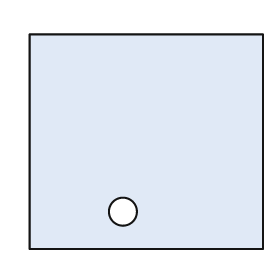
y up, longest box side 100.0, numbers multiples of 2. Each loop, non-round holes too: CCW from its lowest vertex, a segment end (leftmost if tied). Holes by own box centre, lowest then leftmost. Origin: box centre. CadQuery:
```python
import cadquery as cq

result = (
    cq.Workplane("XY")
    .moveTo(-50.0, -46.0)
    .lineTo(50.0, -46.0)
    .lineTo(50.0, 46.0)
    .lineTo(-50.0, 46.0)
    .close()
    .moveTo(-10.0, -30.0)
    .circle(6.0)
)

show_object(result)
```